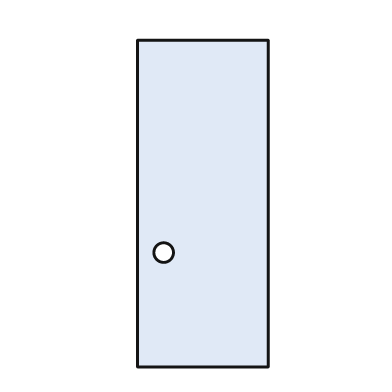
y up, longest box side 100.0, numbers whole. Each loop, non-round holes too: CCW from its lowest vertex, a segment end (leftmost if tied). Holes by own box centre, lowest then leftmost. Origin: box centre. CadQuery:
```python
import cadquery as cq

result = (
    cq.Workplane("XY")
    .moveTo(-20.0, -50.0)
    .lineTo(20.0, -50.0)
    .lineTo(20.0, 50.0)
    .lineTo(-20.0, 50.0)
    .close()
    .moveTo(-12.0, -15.0)
    .circle(3.0)
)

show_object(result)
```